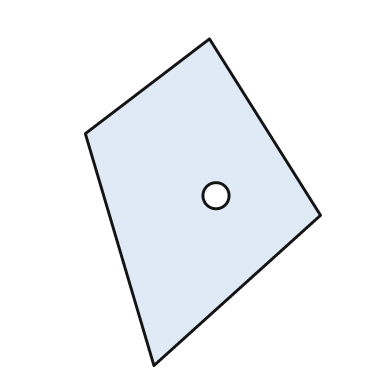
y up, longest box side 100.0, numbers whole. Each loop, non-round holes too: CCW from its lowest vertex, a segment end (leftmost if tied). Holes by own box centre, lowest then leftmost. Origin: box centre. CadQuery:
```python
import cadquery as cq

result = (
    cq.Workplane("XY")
    .moveTo(-15.0, -50.0)
    .lineTo(36.0, -4.0)
    .lineTo(2.0, 50.0)
    .lineTo(-36.0, 21.0)
    .close()
    .moveTo(4.0, 2.0)
    .circle(4.0)
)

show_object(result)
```